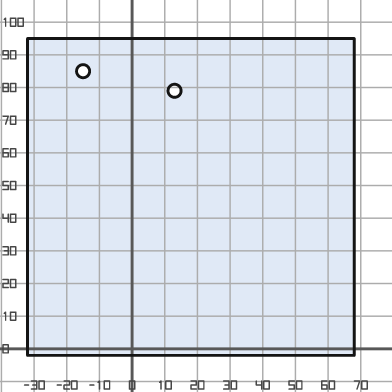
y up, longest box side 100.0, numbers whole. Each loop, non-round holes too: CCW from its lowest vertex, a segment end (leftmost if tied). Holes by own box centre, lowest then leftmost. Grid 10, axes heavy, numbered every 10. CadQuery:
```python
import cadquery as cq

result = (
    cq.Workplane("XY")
    .moveTo(-32.0, -2.0)
    .lineTo(68.0, -2.0)
    .lineTo(68.0, 95.0)
    .lineTo(-32.0, 95.0)
    .close()
    .moveTo(13.0, 79.0)
    .circle(2.0)
    .moveTo(-15.0, 85.0)
    .circle(2.0)
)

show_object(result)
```